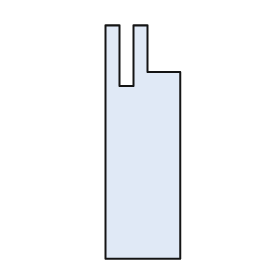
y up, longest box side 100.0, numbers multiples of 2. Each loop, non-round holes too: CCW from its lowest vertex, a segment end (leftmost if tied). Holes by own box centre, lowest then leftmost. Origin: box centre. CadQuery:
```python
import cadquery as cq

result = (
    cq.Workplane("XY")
    .moveTo(-16.0, -50.0)
    .lineTo(16.0, -50.0)
    .lineTo(16.0, 30.0)
    .lineTo(2.0, 30.0)
    .lineTo(2.0, 50.0)
    .lineTo(-4.0, 50.0)
    .lineTo(-4.0, 24.0)
    .lineTo(-10.0, 24.0)
    .lineTo(-10.0, 50.0)
    .lineTo(-16.0, 50.0)
    .close()
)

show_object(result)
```